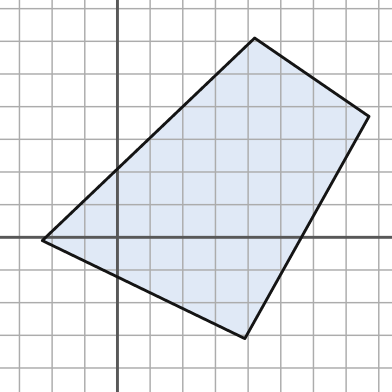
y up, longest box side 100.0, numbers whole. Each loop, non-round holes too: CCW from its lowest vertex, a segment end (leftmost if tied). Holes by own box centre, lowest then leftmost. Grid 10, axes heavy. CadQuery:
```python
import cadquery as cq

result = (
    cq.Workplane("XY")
    .moveTo(39.0, -31.0)
    .lineTo(77.0, 37.0)
    .lineTo(42.0, 61.0)
    .lineTo(-23.0, -1.0)
    .close()
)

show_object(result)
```